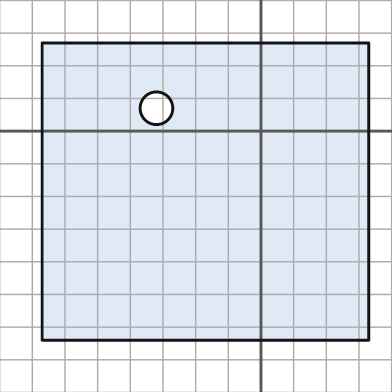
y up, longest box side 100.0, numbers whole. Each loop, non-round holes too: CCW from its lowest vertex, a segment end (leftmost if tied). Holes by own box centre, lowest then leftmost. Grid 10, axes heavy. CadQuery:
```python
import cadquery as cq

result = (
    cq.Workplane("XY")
    .moveTo(-67.0, -64.0)
    .lineTo(33.0, -64.0)
    .lineTo(33.0, 27.0)
    .lineTo(-67.0, 27.0)
    .close()
    .moveTo(-32.0, 7.0)
    .circle(5.0)
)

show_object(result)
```